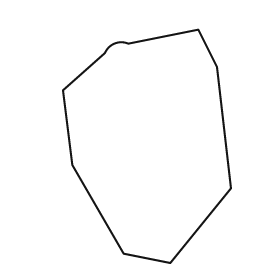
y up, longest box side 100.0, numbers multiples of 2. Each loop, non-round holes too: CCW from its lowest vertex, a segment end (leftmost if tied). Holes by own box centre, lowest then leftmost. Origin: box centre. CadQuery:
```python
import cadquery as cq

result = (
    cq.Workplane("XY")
    .moveTo(10.0, -50.0)
    .lineTo(36.0, -18.0)
    .lineTo(30.0, 34.0)
    .lineTo(22.0, 50.0)
    .lineTo(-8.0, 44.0)
    .threePointArc((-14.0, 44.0), (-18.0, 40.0))
    .lineTo(-36.0, 24.0)
    .lineTo(-32.0, -8.0)
    .lineTo(-10.0, -46.0)
    .close()
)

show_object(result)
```